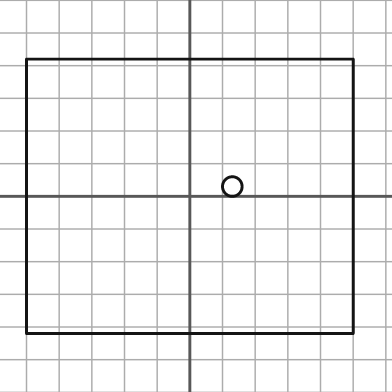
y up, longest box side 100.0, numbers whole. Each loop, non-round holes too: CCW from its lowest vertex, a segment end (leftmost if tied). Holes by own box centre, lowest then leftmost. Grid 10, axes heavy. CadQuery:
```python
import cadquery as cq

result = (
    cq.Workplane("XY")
    .moveTo(-50.0, -42.0)
    .lineTo(50.0, -42.0)
    .lineTo(50.0, 42.0)
    .lineTo(-50.0, 42.0)
    .close()
    .moveTo(13.0, 3.0)
    .circle(3.0)
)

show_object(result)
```